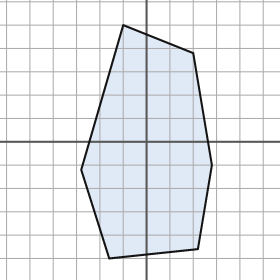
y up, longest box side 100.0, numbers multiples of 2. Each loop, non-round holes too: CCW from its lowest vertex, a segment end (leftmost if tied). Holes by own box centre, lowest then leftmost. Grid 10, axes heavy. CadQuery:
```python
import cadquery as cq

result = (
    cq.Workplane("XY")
    .moveTo(-16.0, -50.0)
    .lineTo(22.0, -46.0)
    .lineTo(28.0, -10.0)
    .lineTo(20.0, 38.0)
    .lineTo(-10.0, 50.0)
    .lineTo(-28.0, -12.0)
    .close()
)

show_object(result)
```